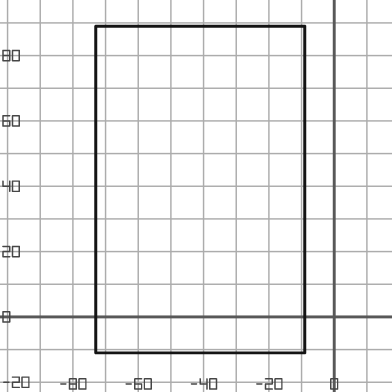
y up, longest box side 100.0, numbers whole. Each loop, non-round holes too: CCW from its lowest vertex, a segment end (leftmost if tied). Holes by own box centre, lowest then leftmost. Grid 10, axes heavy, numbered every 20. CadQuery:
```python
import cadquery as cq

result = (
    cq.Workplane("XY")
    .moveTo(-73.0, -11.0)
    .lineTo(-9.0, -11.0)
    .lineTo(-9.0, 89.0)
    .lineTo(-73.0, 89.0)
    .close()
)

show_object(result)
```